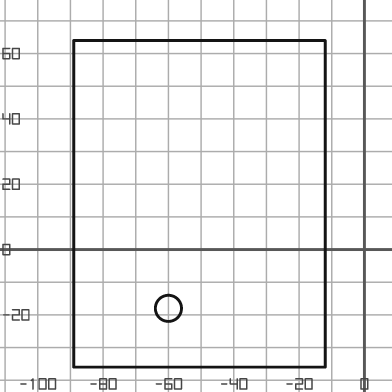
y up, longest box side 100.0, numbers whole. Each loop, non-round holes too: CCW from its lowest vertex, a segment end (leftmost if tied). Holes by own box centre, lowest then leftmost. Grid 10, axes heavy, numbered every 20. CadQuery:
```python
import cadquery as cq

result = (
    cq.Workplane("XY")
    .moveTo(-89.0, -36.0)
    .lineTo(-12.0, -36.0)
    .lineTo(-12.0, 64.0)
    .lineTo(-89.0, 64.0)
    .close()
    .moveTo(-60.0, -18.0)
    .circle(4.0)
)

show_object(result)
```